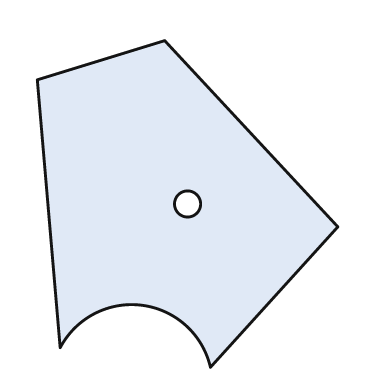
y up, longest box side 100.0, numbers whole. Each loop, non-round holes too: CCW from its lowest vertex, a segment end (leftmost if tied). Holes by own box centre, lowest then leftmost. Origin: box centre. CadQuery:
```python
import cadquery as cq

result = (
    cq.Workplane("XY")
    .moveTo(7.0, -50.0)
    .lineTo(46.0, -7.0)
    .lineTo(-7.0, 50.0)
    .lineTo(-46.0, 38.0)
    .lineTo(-39.0, -44.0)
    .threePointArc((-14.0, -31.0), (7.0, -50.0))
    .close()
    .moveTo(0.0, 0.0)
    .circle(4.0)
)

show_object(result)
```